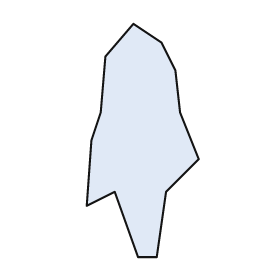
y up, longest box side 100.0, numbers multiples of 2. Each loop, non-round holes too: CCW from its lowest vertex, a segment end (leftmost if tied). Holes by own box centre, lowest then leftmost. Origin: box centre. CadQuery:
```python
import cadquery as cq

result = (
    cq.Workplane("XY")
    .moveTo(-2.0, -50.0)
    .lineTo(6.0, -50.0)
    .lineTo(10.0, -22.0)
    .lineTo(24.0, -8.0)
    .lineTo(16.0, 12.0)
    .lineTo(14.0, 30.0)
    .lineTo(8.0, 42.0)
    .lineTo(-4.0, 50.0)
    .lineTo(-16.0, 36.0)
    .lineTo(-18.0, 12.0)
    .lineTo(-22.0, 0.0)
    .lineTo(-24.0, -28.0)
    .lineTo(-12.0, -22.0)
    .close()
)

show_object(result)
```